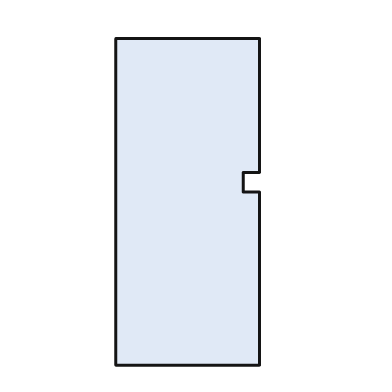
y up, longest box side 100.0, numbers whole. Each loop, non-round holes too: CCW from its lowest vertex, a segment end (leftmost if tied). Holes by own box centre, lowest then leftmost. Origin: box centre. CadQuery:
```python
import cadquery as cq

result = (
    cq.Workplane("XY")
    .moveTo(-22.0, -50.0)
    .lineTo(22.0, -50.0)
    .lineTo(22.0, 3.0)
    .lineTo(17.0, 3.0)
    .lineTo(17.0, 9.0)
    .lineTo(22.0, 9.0)
    .lineTo(22.0, 50.0)
    .lineTo(-22.0, 50.0)
    .close()
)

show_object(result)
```